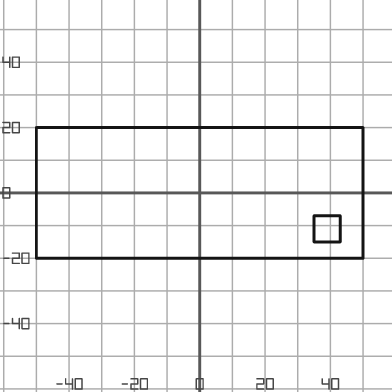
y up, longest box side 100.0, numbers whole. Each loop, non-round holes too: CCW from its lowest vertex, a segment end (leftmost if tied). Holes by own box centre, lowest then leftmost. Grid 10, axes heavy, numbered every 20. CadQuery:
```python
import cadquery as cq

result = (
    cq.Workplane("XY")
    .moveTo(-50.0, -20.0)
    .lineTo(50.0, -20.0)
    .lineTo(50.0, 20.0)
    .lineTo(-50.0, 20.0)
    .close()
    .moveTo(35.0, -15.0)
    .lineTo(43.0, -15.0)
    .lineTo(43.0, -7.0)
    .lineTo(35.0, -7.0)
    .close()
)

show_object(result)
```